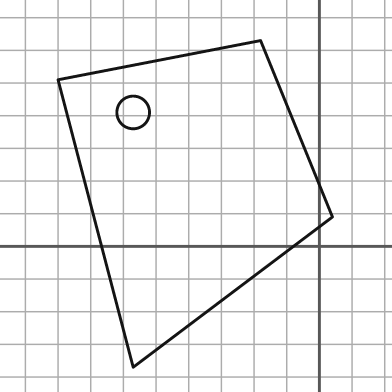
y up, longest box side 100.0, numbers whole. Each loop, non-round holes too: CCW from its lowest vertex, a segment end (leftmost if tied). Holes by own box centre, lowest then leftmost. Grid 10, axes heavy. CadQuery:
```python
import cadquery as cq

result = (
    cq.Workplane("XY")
    .moveTo(-57.0, -37.0)
    .lineTo(4.0, 9.0)
    .lineTo(-18.0, 63.0)
    .lineTo(-80.0, 51.0)
    .close()
    .moveTo(-57.0, 41.0)
    .circle(5.0)
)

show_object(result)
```